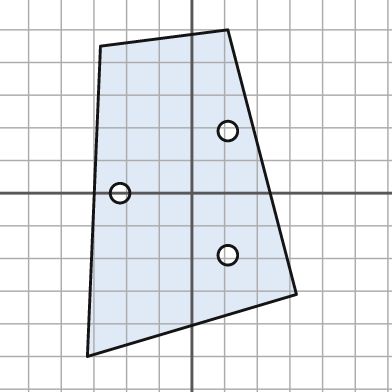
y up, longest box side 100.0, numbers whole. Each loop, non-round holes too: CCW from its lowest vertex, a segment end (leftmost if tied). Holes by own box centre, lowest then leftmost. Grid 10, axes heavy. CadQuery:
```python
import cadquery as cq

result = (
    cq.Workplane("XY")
    .moveTo(-32.0, -50.0)
    .lineTo(32.0, -31.0)
    .lineTo(11.0, 50.0)
    .lineTo(-28.0, 45.0)
    .close()
    .moveTo(11.0, -19.0)
    .circle(3.0)
    .moveTo(-22.0, 0.0)
    .circle(3.0)
    .moveTo(11.0, 19.0)
    .circle(3.0)
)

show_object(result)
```